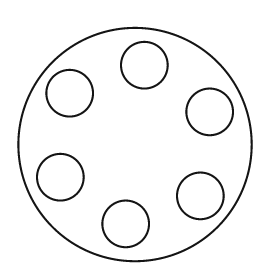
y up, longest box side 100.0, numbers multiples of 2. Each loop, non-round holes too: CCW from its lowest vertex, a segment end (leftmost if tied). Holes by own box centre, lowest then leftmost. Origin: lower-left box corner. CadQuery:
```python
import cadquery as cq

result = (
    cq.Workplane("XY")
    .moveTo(50.0, 50.0)
    .circle(50.0)
    .moveTo(46.0, 16.0)
    .circle(10.0)
    .moveTo(78.0, 28.0)
    .circle(10.0)
    .moveTo(18.0, 36.0)
    .circle(10.0)
    .moveTo(82.0, 64.0)
    .circle(10.0)
    .moveTo(22.0, 72.0)
    .circle(10.0)
    .moveTo(54.0, 84.0)
    .circle(10.0)
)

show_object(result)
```